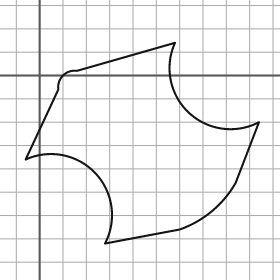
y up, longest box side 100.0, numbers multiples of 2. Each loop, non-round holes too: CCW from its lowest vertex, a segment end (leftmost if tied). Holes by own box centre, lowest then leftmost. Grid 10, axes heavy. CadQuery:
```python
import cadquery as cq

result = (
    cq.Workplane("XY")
    .moveTo(28.0, -72.0)
    .lineTo(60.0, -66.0)
    .threePointArc((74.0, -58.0), (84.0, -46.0))
    .lineTo(94.0, -20.0)
    .threePointArc((64.0, -16.0), (58.0, 14.0))
    .lineTo(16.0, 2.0)
    .threePointArc((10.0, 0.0), (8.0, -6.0))
    .lineTo(-6.0, -36.0)
    .threePointArc((24.0, -42.0), (28.0, -72.0))
    .close()
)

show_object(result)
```